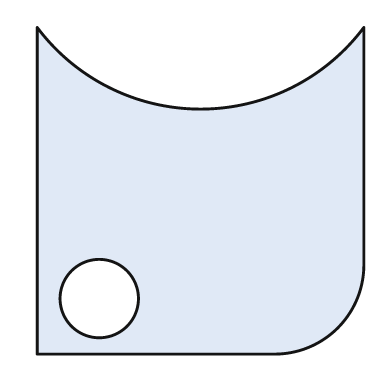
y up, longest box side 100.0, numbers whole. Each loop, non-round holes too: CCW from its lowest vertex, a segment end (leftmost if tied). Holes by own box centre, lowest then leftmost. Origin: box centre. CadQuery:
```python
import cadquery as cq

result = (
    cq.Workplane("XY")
    .moveTo(-50.0, -50.0)
    .lineTo(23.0, -50.0)
    .threePointArc((42.0, -42.0), (50.0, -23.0))
    .lineTo(50.0, 50.0)
    .threePointArc((0.0, 25.0), (-50.0, 50.0))
    .close()
    .moveTo(-31.0, -33.0)
    .circle(12.0)
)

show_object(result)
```